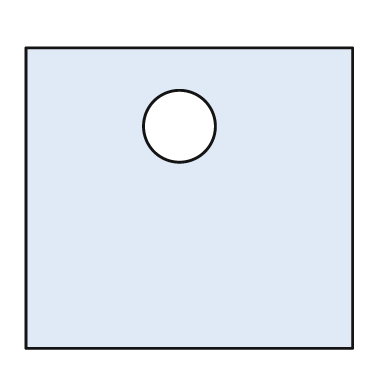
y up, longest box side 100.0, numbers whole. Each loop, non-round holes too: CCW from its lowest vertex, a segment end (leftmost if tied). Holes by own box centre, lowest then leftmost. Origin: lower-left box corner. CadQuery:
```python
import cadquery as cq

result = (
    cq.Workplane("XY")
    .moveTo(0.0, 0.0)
    .lineTo(100.0, 0.0)
    .lineTo(100.0, 92.0)
    .lineTo(0.0, 92.0)
    .close()
    .moveTo(47.0, 68.0)
    .circle(11.0)
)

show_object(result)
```